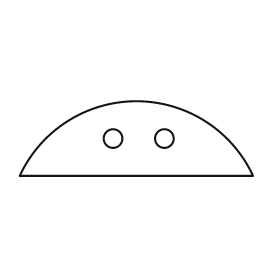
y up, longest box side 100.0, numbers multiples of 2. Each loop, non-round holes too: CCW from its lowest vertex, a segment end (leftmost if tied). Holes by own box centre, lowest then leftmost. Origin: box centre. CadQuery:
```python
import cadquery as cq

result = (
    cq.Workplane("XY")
    .moveTo(-50.0, -16.0)
    .lineTo(50.0, -16.0)
    .threePointArc((0.0, 16.0), (-50.0, -16.0))
    .close()
    .moveTo(-10.0, 0.0)
    .circle(4.0)
    .moveTo(12.0, 0.0)
    .circle(4.0)
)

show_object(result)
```